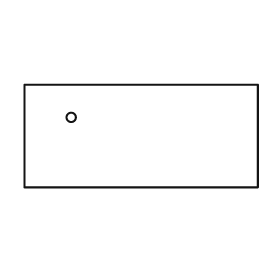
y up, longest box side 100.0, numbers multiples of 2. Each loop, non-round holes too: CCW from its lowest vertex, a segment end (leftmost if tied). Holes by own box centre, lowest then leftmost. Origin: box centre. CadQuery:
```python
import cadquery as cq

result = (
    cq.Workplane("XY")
    .moveTo(-50.0, -22.0)
    .lineTo(50.0, -22.0)
    .lineTo(50.0, 22.0)
    .lineTo(-50.0, 22.0)
    .close()
    .moveTo(-30.0, 8.0)
    .circle(2.0)
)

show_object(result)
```